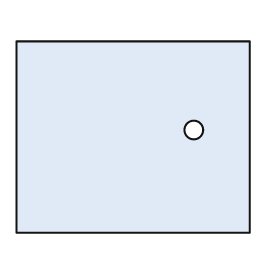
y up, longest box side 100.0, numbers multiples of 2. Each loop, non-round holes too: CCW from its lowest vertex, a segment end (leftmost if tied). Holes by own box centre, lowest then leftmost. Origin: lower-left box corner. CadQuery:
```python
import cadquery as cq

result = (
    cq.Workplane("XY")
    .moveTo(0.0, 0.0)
    .lineTo(100.0, 0.0)
    .lineTo(100.0, 82.0)
    .lineTo(0.0, 82.0)
    .close()
    .moveTo(76.0, 44.0)
    .circle(4.0)
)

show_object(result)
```